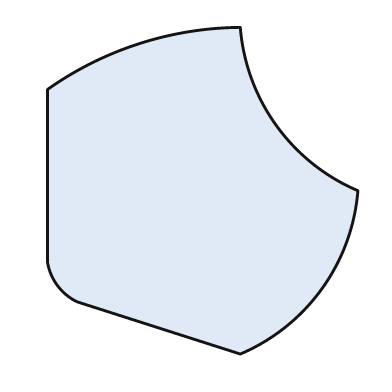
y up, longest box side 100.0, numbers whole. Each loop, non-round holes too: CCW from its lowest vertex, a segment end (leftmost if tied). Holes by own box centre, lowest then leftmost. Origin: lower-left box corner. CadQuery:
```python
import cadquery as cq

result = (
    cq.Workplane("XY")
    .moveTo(59.0, 0.0)
    .threePointArc((84.0, 20.0), (95.0, 50.0))
    .threePointArc((70.0, 70.0), (59.0, 100.0))
    .threePointArc((28.0, 95.0), (0.0, 81.0))
    .lineTo(0.0, 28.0)
    .threePointArc((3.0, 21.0), (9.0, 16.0))
    .close()
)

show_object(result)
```